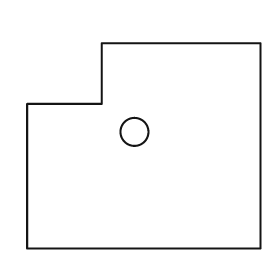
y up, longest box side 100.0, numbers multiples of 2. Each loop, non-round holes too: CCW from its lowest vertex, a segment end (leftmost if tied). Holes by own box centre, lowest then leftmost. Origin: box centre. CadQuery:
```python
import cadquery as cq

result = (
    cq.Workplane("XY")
    .moveTo(-50.0, -44.0)
    .lineTo(50.0, -44.0)
    .lineTo(50.0, 44.0)
    .lineTo(-18.0, 44.0)
    .lineTo(-18.0, 18.0)
    .lineTo(-50.0, 18.0)
    .close()
    .moveTo(-4.0, 6.0)
    .circle(6.0)
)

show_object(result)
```